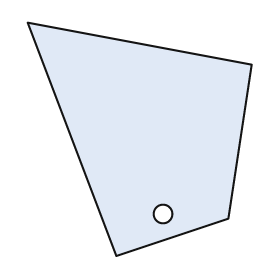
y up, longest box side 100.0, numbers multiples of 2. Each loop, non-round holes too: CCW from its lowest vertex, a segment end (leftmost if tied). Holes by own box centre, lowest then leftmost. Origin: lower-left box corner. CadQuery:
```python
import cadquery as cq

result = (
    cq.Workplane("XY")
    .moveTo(38.0, 0.0)
    .lineTo(86.0, 16.0)
    .lineTo(96.0, 82.0)
    .lineTo(0.0, 100.0)
    .close()
    .moveTo(58.0, 18.0)
    .circle(4.0)
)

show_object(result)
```